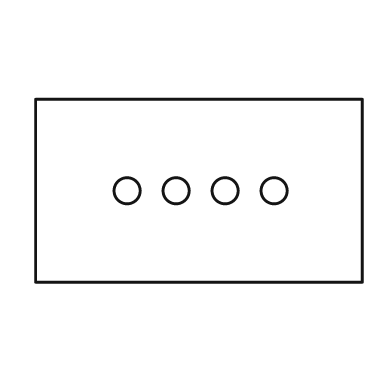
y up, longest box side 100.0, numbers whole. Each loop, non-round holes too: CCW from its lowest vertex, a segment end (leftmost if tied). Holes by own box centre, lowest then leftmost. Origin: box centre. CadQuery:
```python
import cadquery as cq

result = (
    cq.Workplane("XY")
    .moveTo(-50.0, -28.0)
    .lineTo(50.0, -28.0)
    .lineTo(50.0, 28.0)
    .lineTo(-50.0, 28.0)
    .close()
    .moveTo(-22.0, 0.0)
    .circle(4.0)
    .moveTo(-7.0, 0.0)
    .circle(4.0)
    .moveTo(8.0, 0.0)
    .circle(4.0)
    .moveTo(23.0, 0.0)
    .circle(4.0)
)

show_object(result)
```